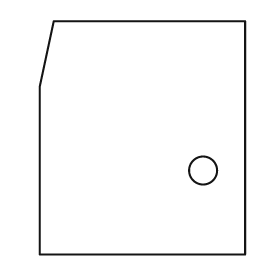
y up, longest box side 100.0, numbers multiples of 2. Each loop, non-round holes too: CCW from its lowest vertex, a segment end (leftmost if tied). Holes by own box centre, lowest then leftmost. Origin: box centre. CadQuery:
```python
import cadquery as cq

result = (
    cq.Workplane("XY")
    .moveTo(-44.0, -50.0)
    .lineTo(44.0, -50.0)
    .lineTo(44.0, 50.0)
    .lineTo(-38.0, 50.0)
    .lineTo(-44.0, 22.0)
    .close()
    .moveTo(26.0, -14.0)
    .circle(6.0)
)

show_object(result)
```